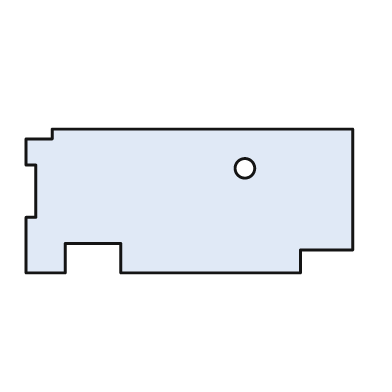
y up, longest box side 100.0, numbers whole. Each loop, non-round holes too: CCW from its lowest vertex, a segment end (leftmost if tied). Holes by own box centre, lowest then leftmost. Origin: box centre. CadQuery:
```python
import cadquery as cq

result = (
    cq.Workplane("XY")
    .moveTo(-50.0, -22.0)
    .lineTo(-38.0, -22.0)
    .lineTo(-38.0, -13.0)
    .lineTo(-21.0, -13.0)
    .lineTo(-21.0, -22.0)
    .lineTo(34.0, -22.0)
    .lineTo(34.0, -15.0)
    .lineTo(50.0, -15.0)
    .lineTo(50.0, 22.0)
    .lineTo(-42.0, 22.0)
    .lineTo(-42.0, 19.0)
    .lineTo(-50.0, 19.0)
    .lineTo(-50.0, 11.0)
    .lineTo(-47.0, 11.0)
    .lineTo(-47.0, -5.0)
    .lineTo(-50.0, -5.0)
    .close()
    .moveTo(17.0, 10.0)
    .circle(3.0)
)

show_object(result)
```